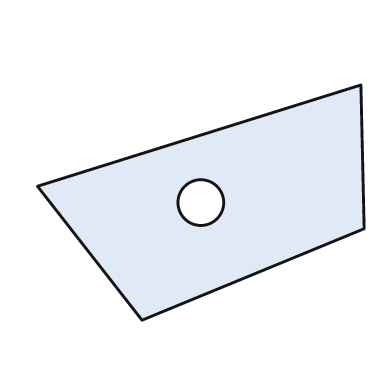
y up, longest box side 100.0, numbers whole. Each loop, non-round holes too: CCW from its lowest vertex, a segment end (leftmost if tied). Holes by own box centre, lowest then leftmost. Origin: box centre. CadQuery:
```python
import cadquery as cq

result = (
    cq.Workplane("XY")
    .moveTo(-18.0, -36.0)
    .lineTo(50.0, -8.0)
    .lineTo(49.0, 36.0)
    .lineTo(-50.0, 5.0)
    .close()
    .moveTo(0.0, 0.0)
    .circle(7.0)
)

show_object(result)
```